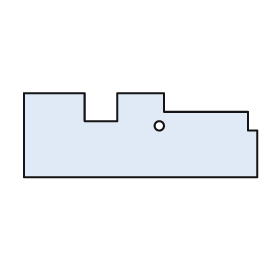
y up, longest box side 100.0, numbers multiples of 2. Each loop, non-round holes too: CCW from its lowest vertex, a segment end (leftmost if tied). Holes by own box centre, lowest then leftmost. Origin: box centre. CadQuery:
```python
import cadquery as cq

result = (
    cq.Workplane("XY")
    .moveTo(-50.0, -18.0)
    .lineTo(50.0, -18.0)
    .lineTo(50.0, 2.0)
    .lineTo(46.0, 2.0)
    .lineTo(46.0, 10.0)
    .lineTo(10.0, 10.0)
    .lineTo(10.0, 18.0)
    .lineTo(-10.0, 18.0)
    .lineTo(-10.0, 6.0)
    .lineTo(-24.0, 6.0)
    .lineTo(-24.0, 18.0)
    .lineTo(-50.0, 18.0)
    .close()
    .moveTo(8.0, 4.0)
    .circle(2.0)
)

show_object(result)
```